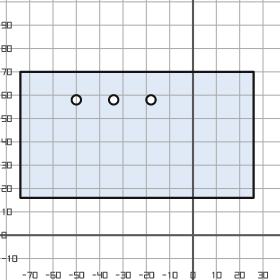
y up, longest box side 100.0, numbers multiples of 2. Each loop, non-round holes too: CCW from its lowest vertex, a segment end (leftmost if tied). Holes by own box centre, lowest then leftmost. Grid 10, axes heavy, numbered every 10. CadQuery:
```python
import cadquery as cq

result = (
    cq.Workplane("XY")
    .moveTo(-74.0, 16.0)
    .lineTo(26.0, 16.0)
    .lineTo(26.0, 70.0)
    .lineTo(-74.0, 70.0)
    .close()
    .moveTo(-50.0, 58.0)
    .circle(2.0)
    .moveTo(-34.0, 58.0)
    .circle(2.0)
    .moveTo(-18.0, 58.0)
    .circle(2.0)
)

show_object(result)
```